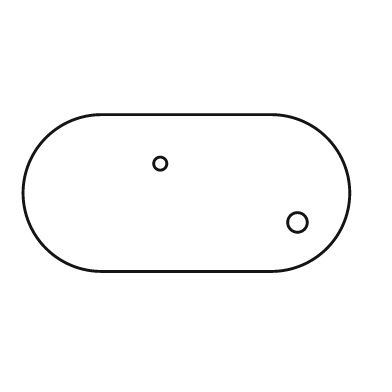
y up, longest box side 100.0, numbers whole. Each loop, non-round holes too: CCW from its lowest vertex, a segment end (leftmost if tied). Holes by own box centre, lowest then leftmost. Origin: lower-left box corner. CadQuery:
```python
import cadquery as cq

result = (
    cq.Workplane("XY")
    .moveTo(24.0, 0.0)
    .lineTo(76.0, 0.0)
    .threePointArc((100.0, 24.0), (76.0, 48.0))
    .lineTo(24.0, 48.0)
    .threePointArc((0.0, 24.0), (24.0, 0.0))
    .close()
    .moveTo(84.0, 15.0)
    .circle(3.0)
    .moveTo(42.0, 33.0)
    .circle(2.0)
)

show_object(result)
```